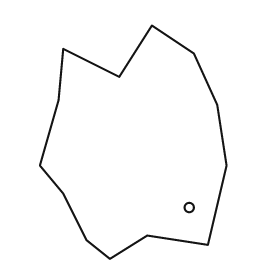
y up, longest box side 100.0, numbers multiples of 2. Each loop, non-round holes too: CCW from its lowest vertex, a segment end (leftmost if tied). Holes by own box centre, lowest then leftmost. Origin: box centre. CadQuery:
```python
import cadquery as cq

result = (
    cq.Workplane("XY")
    .moveTo(-10.0, -50.0)
    .lineTo(6.0, -40.0)
    .lineTo(32.0, -44.0)
    .lineTo(40.0, -10.0)
    .lineTo(36.0, 16.0)
    .lineTo(26.0, 38.0)
    .lineTo(8.0, 50.0)
    .lineTo(-6.0, 28.0)
    .lineTo(-30.0, 40.0)
    .lineTo(-32.0, 18.0)
    .lineTo(-40.0, -10.0)
    .lineTo(-30.0, -22.0)
    .lineTo(-20.0, -42.0)
    .close()
    .moveTo(24.0, -28.0)
    .circle(2.0)
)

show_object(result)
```